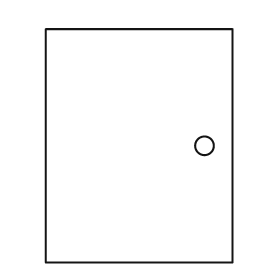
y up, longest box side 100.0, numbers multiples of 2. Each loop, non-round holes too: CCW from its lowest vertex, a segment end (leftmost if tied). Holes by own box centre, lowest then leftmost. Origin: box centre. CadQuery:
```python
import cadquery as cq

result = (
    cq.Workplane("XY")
    .moveTo(-40.0, -50.0)
    .lineTo(40.0, -50.0)
    .lineTo(40.0, 50.0)
    .lineTo(-40.0, 50.0)
    .close()
    .moveTo(28.0, 0.0)
    .circle(4.0)
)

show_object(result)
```